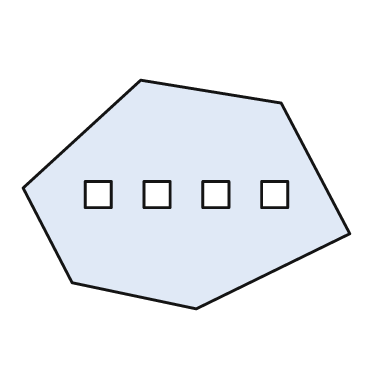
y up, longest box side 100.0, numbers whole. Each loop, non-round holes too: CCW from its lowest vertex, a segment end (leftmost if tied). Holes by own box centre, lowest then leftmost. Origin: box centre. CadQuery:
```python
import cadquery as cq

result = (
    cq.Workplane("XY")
    .moveTo(3.0, -35.0)
    .lineTo(50.0, -12.0)
    .lineTo(29.0, 28.0)
    .lineTo(-14.0, 35.0)
    .lineTo(-50.0, 2.0)
    .lineTo(-35.0, -27.0)
    .close()
    .moveTo(-31.0, -4.0)
    .lineTo(-23.0, -4.0)
    .lineTo(-23.0, 4.0)
    .lineTo(-31.0, 4.0)
    .close()
    .moveTo(-13.0, -4.0)
    .lineTo(-5.0, -4.0)
    .lineTo(-5.0, 4.0)
    .lineTo(-13.0, 4.0)
    .close()
    .moveTo(5.0, -4.0)
    .lineTo(13.0, -4.0)
    .lineTo(13.0, 4.0)
    .lineTo(5.0, 4.0)
    .close()
    .moveTo(23.0, -4.0)
    .lineTo(31.0, -4.0)
    .lineTo(31.0, 4.0)
    .lineTo(23.0, 4.0)
    .close()
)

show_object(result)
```